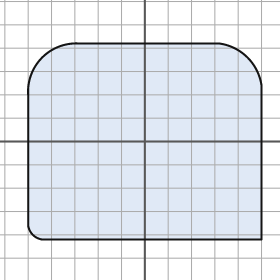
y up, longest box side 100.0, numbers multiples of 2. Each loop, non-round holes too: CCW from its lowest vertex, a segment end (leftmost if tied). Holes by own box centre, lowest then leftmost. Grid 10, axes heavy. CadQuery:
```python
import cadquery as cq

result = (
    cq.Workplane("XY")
    .moveTo(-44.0, -42.0)
    .lineTo(50.0, -42.0)
    .lineTo(50.0, 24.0)
    .threePointArc((44.0, 36.0), (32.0, 42.0))
    .lineTo(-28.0, 42.0)
    .threePointArc((-44.0, 36.0), (-50.0, 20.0))
    .lineTo(-50.0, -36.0)
    .threePointArc((-48.0, -40.0), (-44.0, -42.0))
    .close()
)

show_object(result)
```